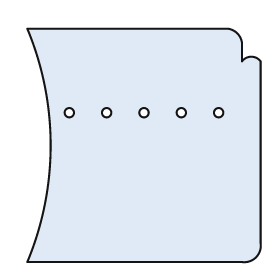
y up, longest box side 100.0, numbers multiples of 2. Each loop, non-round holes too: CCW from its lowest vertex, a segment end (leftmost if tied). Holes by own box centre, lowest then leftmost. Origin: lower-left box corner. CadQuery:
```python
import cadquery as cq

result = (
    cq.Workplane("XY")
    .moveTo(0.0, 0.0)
    .lineTo(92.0, 0.0)
    .threePointArc((98.0, 2.0), (100.0, 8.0))
    .lineTo(100.0, 86.0)
    .threePointArc((96.0, 88.0), (92.0, 86.0))
    .lineTo(92.0, 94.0)
    .threePointArc((90.0, 98.0), (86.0, 100.0))
    .lineTo(0.0, 100.0)
    .threePointArc((10.0, 50.0), (0.0, 0.0))
    .close()
    .moveTo(18.0, 64.0)
    .circle(2.0)
    .moveTo(34.0, 64.0)
    .circle(2.0)
    .moveTo(50.0, 64.0)
    .circle(2.0)
    .moveTo(66.0, 64.0)
    .circle(2.0)
    .moveTo(82.0, 64.0)
    .circle(2.0)
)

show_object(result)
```